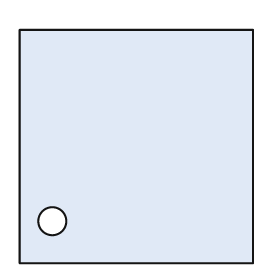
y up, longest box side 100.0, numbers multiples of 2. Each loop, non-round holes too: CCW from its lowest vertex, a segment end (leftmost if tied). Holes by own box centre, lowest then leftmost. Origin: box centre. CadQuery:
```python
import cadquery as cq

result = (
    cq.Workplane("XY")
    .moveTo(-50.0, -50.0)
    .lineTo(50.0, -50.0)
    .lineTo(50.0, 50.0)
    .lineTo(-50.0, 50.0)
    .close()
    .moveTo(-36.0, -32.0)
    .circle(6.0)
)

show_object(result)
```